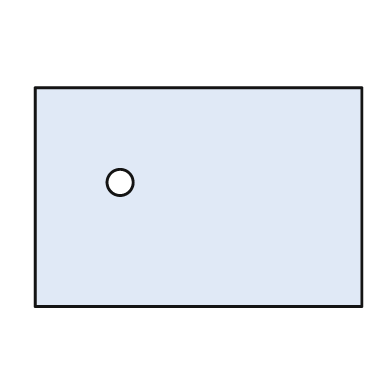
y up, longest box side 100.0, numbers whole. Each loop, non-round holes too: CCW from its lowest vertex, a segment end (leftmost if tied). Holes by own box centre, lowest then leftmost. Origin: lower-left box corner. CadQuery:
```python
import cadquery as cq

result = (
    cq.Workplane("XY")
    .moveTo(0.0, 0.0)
    .lineTo(100.0, 0.0)
    .lineTo(100.0, 67.0)
    .lineTo(0.0, 67.0)
    .close()
    .moveTo(26.0, 38.0)
    .circle(4.0)
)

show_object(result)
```